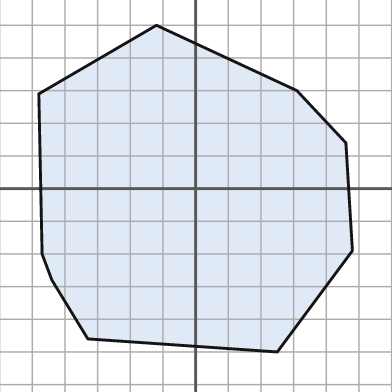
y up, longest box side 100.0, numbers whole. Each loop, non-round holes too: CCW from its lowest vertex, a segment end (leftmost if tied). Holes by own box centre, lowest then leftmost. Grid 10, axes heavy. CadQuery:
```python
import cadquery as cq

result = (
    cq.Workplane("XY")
    .moveTo(25.0, -50.0)
    .lineTo(48.0, -19.0)
    .lineTo(46.0, 14.0)
    .lineTo(31.0, 30.0)
    .lineTo(-12.0, 50.0)
    .lineTo(-48.0, 29.0)
    .lineTo(-47.0, -20.0)
    .lineTo(-44.0, -28.0)
    .lineTo(-33.0, -46.0)
    .close()
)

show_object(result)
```